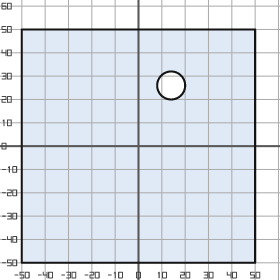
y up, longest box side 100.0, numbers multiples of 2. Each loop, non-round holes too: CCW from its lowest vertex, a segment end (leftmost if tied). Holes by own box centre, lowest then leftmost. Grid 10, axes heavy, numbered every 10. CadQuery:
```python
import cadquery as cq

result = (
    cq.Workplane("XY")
    .moveTo(-50.0, -50.0)
    .lineTo(50.0, -50.0)
    .lineTo(50.0, 50.0)
    .lineTo(-50.0, 50.0)
    .close()
    .moveTo(14.0, 26.0)
    .circle(6.0)
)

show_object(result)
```